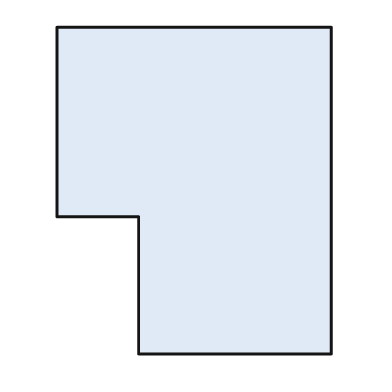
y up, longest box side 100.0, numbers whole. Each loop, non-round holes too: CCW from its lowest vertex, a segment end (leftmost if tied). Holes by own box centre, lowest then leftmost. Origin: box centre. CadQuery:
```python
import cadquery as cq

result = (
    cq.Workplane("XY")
    .moveTo(-17.0, -50.0)
    .lineTo(42.0, -50.0)
    .lineTo(42.0, 50.0)
    .lineTo(-42.0, 50.0)
    .lineTo(-42.0, -8.0)
    .lineTo(-17.0, -8.0)
    .close()
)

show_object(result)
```